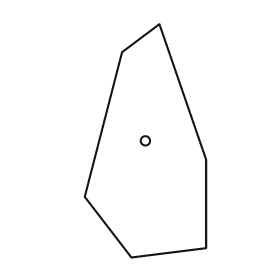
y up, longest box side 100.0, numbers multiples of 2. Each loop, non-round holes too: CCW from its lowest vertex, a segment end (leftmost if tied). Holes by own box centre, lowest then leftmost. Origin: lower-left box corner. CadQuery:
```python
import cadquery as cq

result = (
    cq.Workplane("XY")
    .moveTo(20.0, 0.0)
    .lineTo(52.0, 4.0)
    .lineTo(52.0, 42.0)
    .lineTo(32.0, 100.0)
    .lineTo(16.0, 88.0)
    .lineTo(0.0, 26.0)
    .close()
    .moveTo(26.0, 50.0)
    .circle(2.0)
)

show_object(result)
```